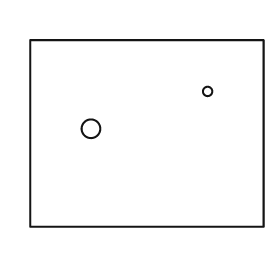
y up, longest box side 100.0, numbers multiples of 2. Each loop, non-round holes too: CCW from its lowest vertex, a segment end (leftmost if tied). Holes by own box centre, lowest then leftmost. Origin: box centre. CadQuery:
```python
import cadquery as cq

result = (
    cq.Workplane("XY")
    .moveTo(-50.0, -40.0)
    .lineTo(50.0, -40.0)
    .lineTo(50.0, 40.0)
    .lineTo(-50.0, 40.0)
    .close()
    .moveTo(-24.0, 2.0)
    .circle(4.0)
    .moveTo(26.0, 18.0)
    .circle(2.0)
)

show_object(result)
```